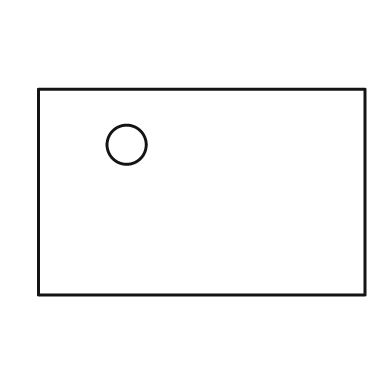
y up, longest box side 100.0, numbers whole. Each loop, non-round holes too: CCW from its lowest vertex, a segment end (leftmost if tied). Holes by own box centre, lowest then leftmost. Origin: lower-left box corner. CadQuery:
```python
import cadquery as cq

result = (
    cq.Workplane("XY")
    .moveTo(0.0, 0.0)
    .lineTo(100.0, 0.0)
    .lineTo(100.0, 63.0)
    .lineTo(0.0, 63.0)
    .close()
    .moveTo(27.0, 46.0)
    .circle(6.0)
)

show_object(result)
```